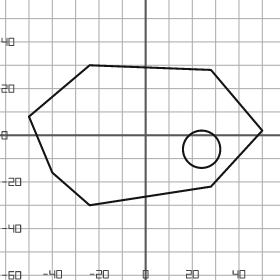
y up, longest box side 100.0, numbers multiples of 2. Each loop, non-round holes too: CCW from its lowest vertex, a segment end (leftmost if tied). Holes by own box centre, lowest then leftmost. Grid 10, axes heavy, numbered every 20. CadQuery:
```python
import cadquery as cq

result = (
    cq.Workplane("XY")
    .moveTo(-24.0, -30.0)
    .lineTo(28.0, -22.0)
    .lineTo(50.0, 2.0)
    .lineTo(28.0, 28.0)
    .lineTo(-24.0, 30.0)
    .lineTo(-50.0, 8.0)
    .lineTo(-40.0, -16.0)
    .close()
    .moveTo(24.0, -6.0)
    .circle(8.0)
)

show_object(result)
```